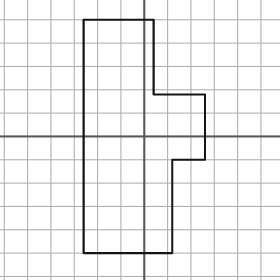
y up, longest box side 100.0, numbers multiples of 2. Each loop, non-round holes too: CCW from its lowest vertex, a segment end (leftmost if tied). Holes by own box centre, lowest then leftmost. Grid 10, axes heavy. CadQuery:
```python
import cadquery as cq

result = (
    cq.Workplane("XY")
    .moveTo(-26.0, -50.0)
    .lineTo(12.0, -50.0)
    .lineTo(12.0, -10.0)
    .lineTo(26.0, -10.0)
    .lineTo(26.0, 18.0)
    .lineTo(4.0, 18.0)
    .lineTo(4.0, 50.0)
    .lineTo(-26.0, 50.0)
    .close()
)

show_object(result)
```